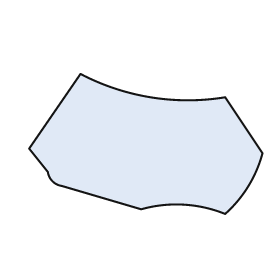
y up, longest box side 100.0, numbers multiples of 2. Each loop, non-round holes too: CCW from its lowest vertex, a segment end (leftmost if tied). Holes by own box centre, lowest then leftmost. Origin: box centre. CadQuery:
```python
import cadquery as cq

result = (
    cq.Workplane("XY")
    .moveTo(34.0, -30.0)
    .threePointArc((44.0, -18.0), (50.0, -4.0))
    .lineTo(34.0, 20.0)
    .threePointArc((2.0, 20.0), (-28.0, 30.0))
    .lineTo(-50.0, -2.0)
    .lineTo(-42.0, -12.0)
    .threePointArc((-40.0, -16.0), (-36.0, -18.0))
    .lineTo(-2.0, -28.0)
    .threePointArc((16.0, -26.0), (34.0, -30.0))
    .close()
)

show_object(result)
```